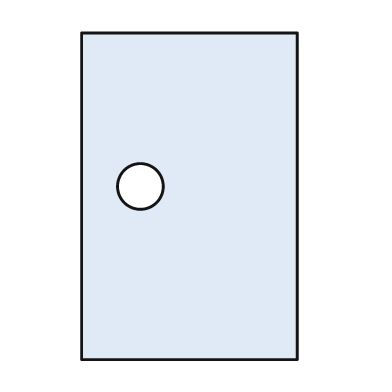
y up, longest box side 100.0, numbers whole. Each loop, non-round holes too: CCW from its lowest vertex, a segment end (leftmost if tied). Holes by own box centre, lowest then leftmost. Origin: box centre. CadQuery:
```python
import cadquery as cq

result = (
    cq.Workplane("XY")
    .moveTo(-33.0, -50.0)
    .lineTo(33.0, -50.0)
    .lineTo(33.0, 50.0)
    .lineTo(-33.0, 50.0)
    .close()
    .moveTo(-15.0, 3.0)
    .circle(7.0)
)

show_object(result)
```